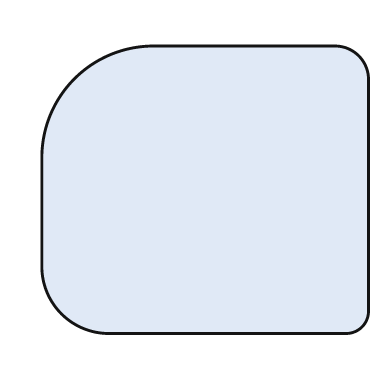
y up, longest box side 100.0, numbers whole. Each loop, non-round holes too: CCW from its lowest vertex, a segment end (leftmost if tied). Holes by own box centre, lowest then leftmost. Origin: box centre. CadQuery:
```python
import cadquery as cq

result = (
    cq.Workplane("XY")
    .moveTo(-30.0, -44.0)
    .lineTo(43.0, -44.0)
    .threePointArc((48.0, -42.0), (50.0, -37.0))
    .lineTo(50.0, 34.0)
    .threePointArc((47.0, 41.0), (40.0, 44.0))
    .lineTo(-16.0, 44.0)
    .threePointArc((-40.0, 34.0), (-50.0, 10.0))
    .lineTo(-50.0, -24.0)
    .threePointArc((-44.0, -38.0), (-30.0, -44.0))
    .close()
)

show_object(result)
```